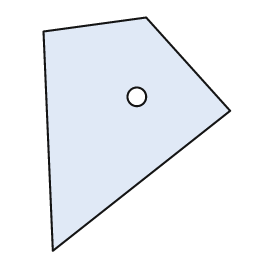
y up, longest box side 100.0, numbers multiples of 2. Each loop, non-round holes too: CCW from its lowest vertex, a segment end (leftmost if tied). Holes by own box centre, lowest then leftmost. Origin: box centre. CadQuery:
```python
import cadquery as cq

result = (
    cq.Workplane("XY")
    .moveTo(-36.0, -50.0)
    .lineTo(40.0, 10.0)
    .lineTo(4.0, 50.0)
    .lineTo(-40.0, 44.0)
    .close()
    .moveTo(0.0, 16.0)
    .circle(4.0)
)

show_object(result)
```